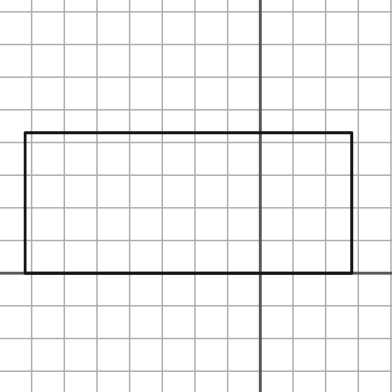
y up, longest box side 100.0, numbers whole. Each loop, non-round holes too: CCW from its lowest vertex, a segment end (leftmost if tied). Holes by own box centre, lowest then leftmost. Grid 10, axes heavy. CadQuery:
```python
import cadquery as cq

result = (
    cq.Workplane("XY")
    .moveTo(-72.0, 0.0)
    .lineTo(28.0, 0.0)
    .lineTo(28.0, 43.0)
    .lineTo(-72.0, 43.0)
    .close()
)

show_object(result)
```